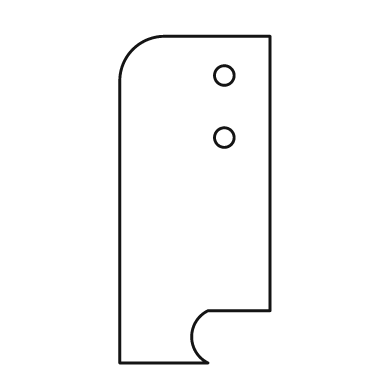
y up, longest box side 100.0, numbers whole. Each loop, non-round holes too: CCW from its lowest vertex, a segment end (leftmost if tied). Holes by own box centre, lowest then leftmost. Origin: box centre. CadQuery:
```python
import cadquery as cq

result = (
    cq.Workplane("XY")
    .moveTo(-23.0, -50.0)
    .lineTo(4.0, -50.0)
    .threePointArc((-1.0, -42.0), (4.0, -34.0))
    .lineTo(23.0, -34.0)
    .lineTo(23.0, 50.0)
    .lineTo(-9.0, 50.0)
    .threePointArc((-19.0, 46.0), (-23.0, 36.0))
    .close()
    .moveTo(9.0, 19.0)
    .circle(3.0)
    .moveTo(9.0, 38.0)
    .circle(3.0)
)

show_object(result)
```